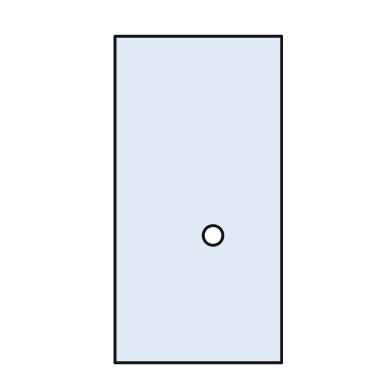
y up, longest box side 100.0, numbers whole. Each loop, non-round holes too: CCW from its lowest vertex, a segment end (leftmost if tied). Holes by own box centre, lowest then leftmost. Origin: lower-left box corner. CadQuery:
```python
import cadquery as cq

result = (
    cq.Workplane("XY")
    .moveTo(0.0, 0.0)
    .lineTo(51.0, 0.0)
    .lineTo(51.0, 100.0)
    .lineTo(0.0, 100.0)
    .close()
    .moveTo(30.0, 39.0)
    .circle(3.0)
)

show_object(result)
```